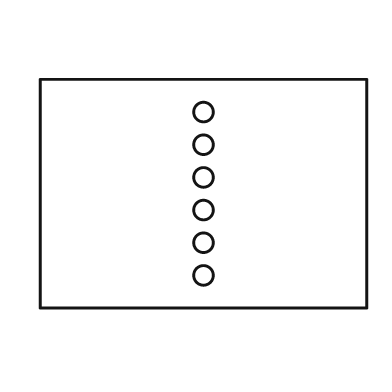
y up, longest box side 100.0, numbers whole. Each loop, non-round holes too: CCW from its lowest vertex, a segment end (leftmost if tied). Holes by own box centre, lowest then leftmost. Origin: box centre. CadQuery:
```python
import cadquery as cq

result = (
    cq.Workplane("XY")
    .moveTo(-50.0, -35.0)
    .lineTo(50.0, -35.0)
    .lineTo(50.0, 35.0)
    .lineTo(-50.0, 35.0)
    .close()
    .moveTo(0.0, -25.0)
    .circle(3.0)
    .moveTo(0.0, -15.0)
    .circle(3.0)
    .moveTo(0.0, -5.0)
    .circle(3.0)
    .moveTo(0.0, 5.0)
    .circle(3.0)
    .moveTo(0.0, 15.0)
    .circle(3.0)
    .moveTo(0.0, 25.0)
    .circle(3.0)
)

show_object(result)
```